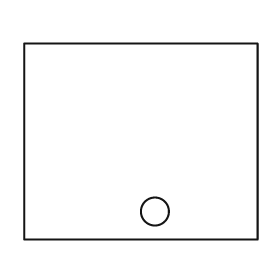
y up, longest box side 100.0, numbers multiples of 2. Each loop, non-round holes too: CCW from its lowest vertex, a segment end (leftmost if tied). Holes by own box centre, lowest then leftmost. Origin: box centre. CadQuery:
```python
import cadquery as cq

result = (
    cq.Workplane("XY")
    .moveTo(-50.0, -42.0)
    .lineTo(50.0, -42.0)
    .lineTo(50.0, 42.0)
    .lineTo(-50.0, 42.0)
    .close()
    .moveTo(6.0, -30.0)
    .circle(6.0)
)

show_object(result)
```